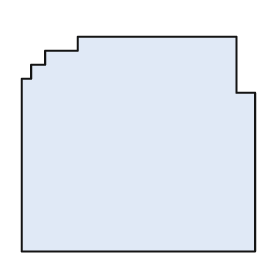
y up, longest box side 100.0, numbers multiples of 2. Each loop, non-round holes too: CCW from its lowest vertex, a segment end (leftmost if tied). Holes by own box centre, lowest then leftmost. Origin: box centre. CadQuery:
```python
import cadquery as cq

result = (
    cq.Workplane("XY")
    .moveTo(-50.0, -46.0)
    .lineTo(50.0, -46.0)
    .lineTo(50.0, 22.0)
    .lineTo(42.0, 22.0)
    .lineTo(42.0, 46.0)
    .lineTo(-26.0, 46.0)
    .lineTo(-26.0, 40.0)
    .lineTo(-40.0, 40.0)
    .lineTo(-40.0, 34.0)
    .lineTo(-46.0, 34.0)
    .lineTo(-46.0, 28.0)
    .lineTo(-50.0, 28.0)
    .close()
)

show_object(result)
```